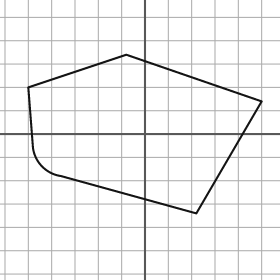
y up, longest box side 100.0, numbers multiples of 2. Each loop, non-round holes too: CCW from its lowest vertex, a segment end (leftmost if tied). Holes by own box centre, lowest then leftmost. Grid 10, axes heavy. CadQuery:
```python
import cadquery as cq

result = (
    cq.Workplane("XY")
    .moveTo(22.0, -34.0)
    .lineTo(50.0, 14.0)
    .lineTo(-8.0, 34.0)
    .lineTo(-50.0, 20.0)
    .lineTo(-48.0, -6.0)
    .threePointArc((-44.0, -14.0), (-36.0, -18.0))
    .close()
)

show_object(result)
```